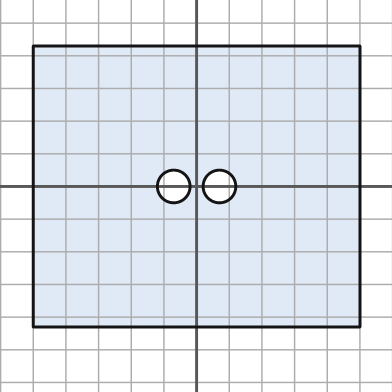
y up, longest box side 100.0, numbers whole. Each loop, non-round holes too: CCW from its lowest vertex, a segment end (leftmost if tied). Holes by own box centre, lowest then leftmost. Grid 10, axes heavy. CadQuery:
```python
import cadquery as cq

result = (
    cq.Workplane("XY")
    .moveTo(-50.0, -43.0)
    .lineTo(50.0, -43.0)
    .lineTo(50.0, 43.0)
    .lineTo(-50.0, 43.0)
    .close()
    .moveTo(-7.0, 0.0)
    .circle(5.0)
    .moveTo(7.0, 0.0)
    .circle(5.0)
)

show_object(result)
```